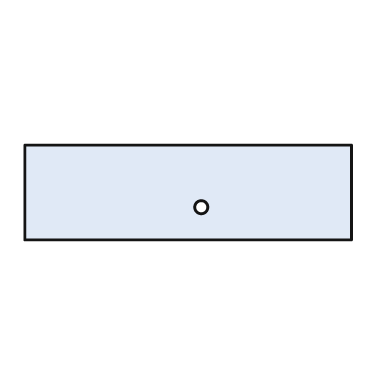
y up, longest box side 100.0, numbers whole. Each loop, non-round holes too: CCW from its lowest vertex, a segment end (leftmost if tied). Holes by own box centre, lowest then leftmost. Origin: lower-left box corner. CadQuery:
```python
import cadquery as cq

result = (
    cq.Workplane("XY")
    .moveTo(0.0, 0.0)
    .lineTo(100.0, 0.0)
    .lineTo(100.0, 29.0)
    .lineTo(0.0, 29.0)
    .close()
    .moveTo(54.0, 10.0)
    .circle(2.0)
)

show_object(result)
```